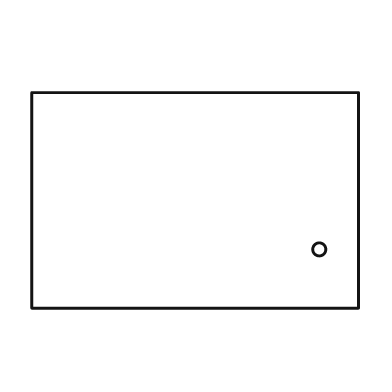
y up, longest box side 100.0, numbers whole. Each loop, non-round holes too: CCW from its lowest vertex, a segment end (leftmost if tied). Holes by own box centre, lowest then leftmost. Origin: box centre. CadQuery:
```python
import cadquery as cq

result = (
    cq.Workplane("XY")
    .moveTo(-50.0, -33.0)
    .lineTo(50.0, -33.0)
    .lineTo(50.0, 33.0)
    .lineTo(-50.0, 33.0)
    .close()
    .moveTo(38.0, -15.0)
    .circle(2.0)
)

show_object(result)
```